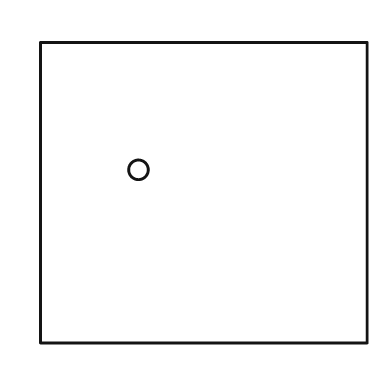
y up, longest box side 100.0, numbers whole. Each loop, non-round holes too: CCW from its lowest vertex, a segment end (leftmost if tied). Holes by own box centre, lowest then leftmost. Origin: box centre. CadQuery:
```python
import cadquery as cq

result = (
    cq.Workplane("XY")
    .moveTo(-50.0, -46.0)
    .lineTo(50.0, -46.0)
    .lineTo(50.0, 46.0)
    .lineTo(-50.0, 46.0)
    .close()
    .moveTo(-20.0, 7.0)
    .circle(3.0)
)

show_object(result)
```